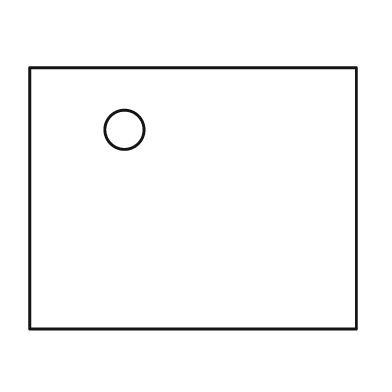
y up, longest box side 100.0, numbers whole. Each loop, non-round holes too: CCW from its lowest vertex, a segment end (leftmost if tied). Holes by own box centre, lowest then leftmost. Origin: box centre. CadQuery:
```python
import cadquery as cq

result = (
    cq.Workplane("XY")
    .moveTo(-50.0, -40.0)
    .lineTo(50.0, -40.0)
    .lineTo(50.0, 40.0)
    .lineTo(-50.0, 40.0)
    .close()
    .moveTo(-21.0, 21.0)
    .circle(6.0)
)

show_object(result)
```